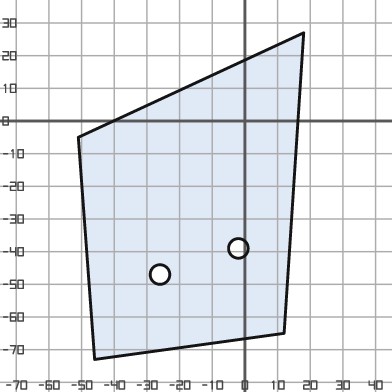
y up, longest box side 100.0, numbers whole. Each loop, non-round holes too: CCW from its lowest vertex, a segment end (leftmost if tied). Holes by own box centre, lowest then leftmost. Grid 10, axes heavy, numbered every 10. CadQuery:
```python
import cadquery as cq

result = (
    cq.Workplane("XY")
    .moveTo(-46.0, -73.0)
    .lineTo(12.0, -65.0)
    .lineTo(18.0, 27.0)
    .lineTo(-51.0, -5.0)
    .close()
    .moveTo(-26.0, -47.0)
    .circle(3.0)
    .moveTo(-2.0, -39.0)
    .circle(3.0)
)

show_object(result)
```